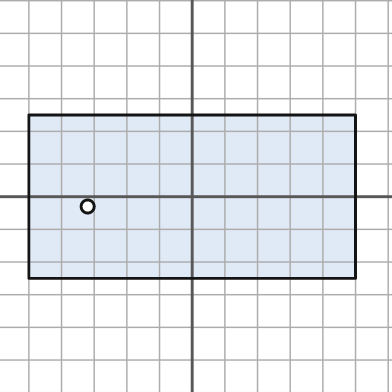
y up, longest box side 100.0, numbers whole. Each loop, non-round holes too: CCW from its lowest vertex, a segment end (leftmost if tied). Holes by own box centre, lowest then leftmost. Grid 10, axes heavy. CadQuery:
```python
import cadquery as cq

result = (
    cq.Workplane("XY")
    .moveTo(-50.0, -25.0)
    .lineTo(50.0, -25.0)
    .lineTo(50.0, 25.0)
    .lineTo(-50.0, 25.0)
    .close()
    .moveTo(-32.0, -3.0)
    .circle(2.0)
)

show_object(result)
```